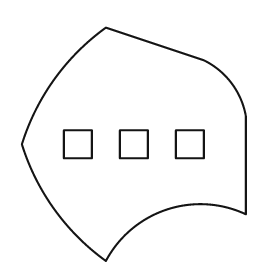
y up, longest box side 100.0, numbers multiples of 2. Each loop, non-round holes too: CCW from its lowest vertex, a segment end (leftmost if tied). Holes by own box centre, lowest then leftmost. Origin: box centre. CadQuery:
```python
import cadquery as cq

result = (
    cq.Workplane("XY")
    .moveTo(-12.0, -50.0)
    .threePointArc((14.0, -28.0), (48.0, -30.0))
    .lineTo(48.0, 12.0)
    .threePointArc((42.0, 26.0), (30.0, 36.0))
    .lineTo(-12.0, 50.0)
    .threePointArc((-34.0, 28.0), (-48.0, 0.0))
    .threePointArc((-34.0, -28.0), (-12.0, -50.0))
    .close()
    .moveTo(-30.0, -6.0)
    .lineTo(-18.0, -6.0)
    .lineTo(-18.0, 6.0)
    .lineTo(-30.0, 6.0)
    .close()
    .moveTo(-6.0, -6.0)
    .lineTo(6.0, -6.0)
    .lineTo(6.0, 6.0)
    .lineTo(-6.0, 6.0)
    .close()
    .moveTo(18.0, -6.0)
    .lineTo(30.0, -6.0)
    .lineTo(30.0, 6.0)
    .lineTo(18.0, 6.0)
    .close()
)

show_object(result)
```